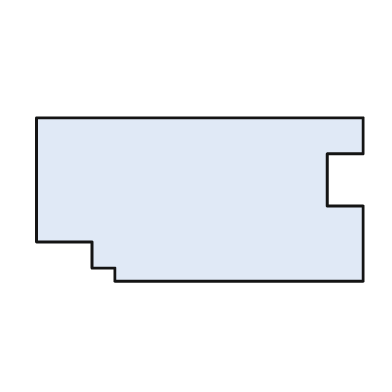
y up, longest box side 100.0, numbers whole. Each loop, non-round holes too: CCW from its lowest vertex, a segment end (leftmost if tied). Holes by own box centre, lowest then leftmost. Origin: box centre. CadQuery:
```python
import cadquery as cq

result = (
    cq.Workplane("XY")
    .moveTo(-26.0, -25.0)
    .lineTo(50.0, -25.0)
    .lineTo(50.0, -2.0)
    .lineTo(39.0, -2.0)
    .lineTo(39.0, 14.0)
    .lineTo(50.0, 14.0)
    .lineTo(50.0, 25.0)
    .lineTo(-50.0, 25.0)
    .lineTo(-50.0, -13.0)
    .lineTo(-33.0, -13.0)
    .lineTo(-33.0, -21.0)
    .lineTo(-26.0, -21.0)
    .close()
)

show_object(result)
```